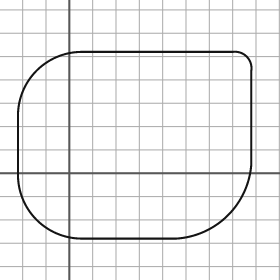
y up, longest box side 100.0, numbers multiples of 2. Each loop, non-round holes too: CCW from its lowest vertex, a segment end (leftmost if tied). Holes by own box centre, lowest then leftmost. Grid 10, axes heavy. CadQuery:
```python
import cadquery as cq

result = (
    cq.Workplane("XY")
    .moveTo(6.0, -28.0)
    .lineTo(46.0, -28.0)
    .threePointArc((68.0, -18.0), (78.0, 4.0))
    .lineTo(78.0, 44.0)
    .threePointArc((76.0, 50.0), (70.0, 52.0))
    .lineTo(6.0, 52.0)
    .threePointArc((-14.0, 44.0), (-22.0, 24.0))
    .lineTo(-22.0, 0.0)
    .threePointArc((-14.0, -20.0), (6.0, -28.0))
    .close()
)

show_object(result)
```